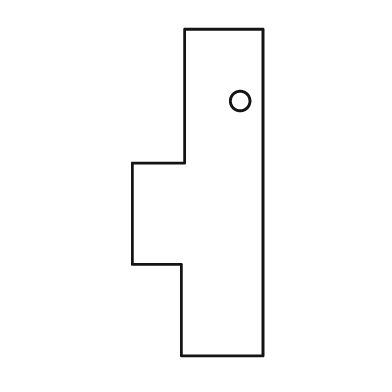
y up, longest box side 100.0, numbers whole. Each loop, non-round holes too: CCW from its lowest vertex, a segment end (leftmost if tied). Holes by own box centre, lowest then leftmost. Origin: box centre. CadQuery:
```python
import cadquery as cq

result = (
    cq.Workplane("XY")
    .moveTo(-5.0, -50.0)
    .lineTo(20.0, -50.0)
    .lineTo(20.0, 50.0)
    .lineTo(-4.0, 50.0)
    .lineTo(-4.0, 9.0)
    .lineTo(-20.0, 9.0)
    .lineTo(-20.0, -22.0)
    .lineTo(-5.0, -22.0)
    .close()
    .moveTo(13.0, 28.0)
    .circle(3.0)
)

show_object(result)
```